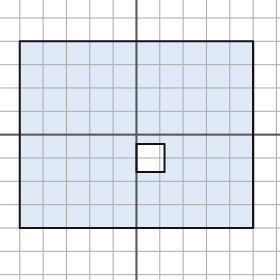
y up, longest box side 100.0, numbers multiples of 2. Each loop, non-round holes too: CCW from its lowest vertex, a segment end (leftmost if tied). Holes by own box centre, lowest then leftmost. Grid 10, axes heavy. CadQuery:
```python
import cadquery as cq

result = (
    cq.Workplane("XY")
    .moveTo(-50.0, -40.0)
    .lineTo(50.0, -40.0)
    .lineTo(50.0, 40.0)
    .lineTo(-50.0, 40.0)
    .close()
    .moveTo(0.0, -16.0)
    .lineTo(12.0, -16.0)
    .lineTo(12.0, -4.0)
    .lineTo(0.0, -4.0)
    .close()
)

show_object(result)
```